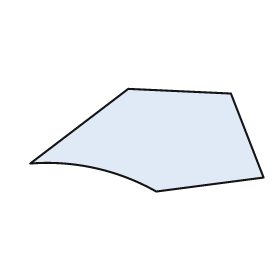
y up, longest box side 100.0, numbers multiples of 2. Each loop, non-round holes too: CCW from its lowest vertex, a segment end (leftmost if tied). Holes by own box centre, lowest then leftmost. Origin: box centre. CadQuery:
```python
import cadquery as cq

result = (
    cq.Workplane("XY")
    .moveTo(4.0, -22.0)
    .lineTo(50.0, -16.0)
    .lineTo(36.0, 20.0)
    .lineTo(-8.0, 22.0)
    .lineTo(-50.0, -10.0)
    .threePointArc((-22.0, -12.0), (4.0, -22.0))
    .close()
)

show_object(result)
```